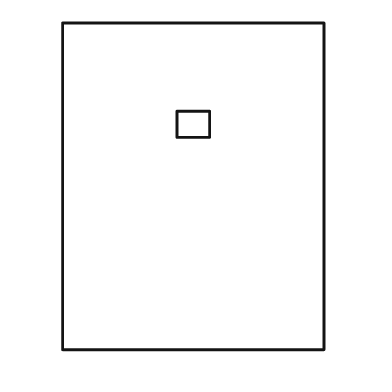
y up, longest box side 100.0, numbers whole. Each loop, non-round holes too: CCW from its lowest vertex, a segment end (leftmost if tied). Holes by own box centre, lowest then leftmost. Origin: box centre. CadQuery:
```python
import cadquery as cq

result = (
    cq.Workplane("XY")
    .moveTo(-40.0, -50.0)
    .lineTo(40.0, -50.0)
    .lineTo(40.0, 50.0)
    .lineTo(-40.0, 50.0)
    .close()
    .moveTo(-5.0, 15.0)
    .lineTo(5.0, 15.0)
    .lineTo(5.0, 23.0)
    .lineTo(-5.0, 23.0)
    .close()
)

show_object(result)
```